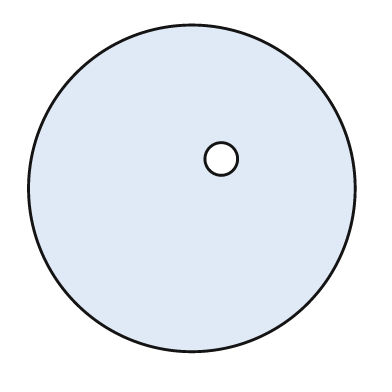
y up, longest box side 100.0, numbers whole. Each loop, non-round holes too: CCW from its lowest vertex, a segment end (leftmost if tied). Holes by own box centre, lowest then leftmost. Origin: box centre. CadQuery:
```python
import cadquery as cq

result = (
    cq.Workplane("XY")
    .moveTo(0.0, 0.0)
    .circle(50.0)
    .moveTo(9.0, 9.0)
    .circle(5.0)
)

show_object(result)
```